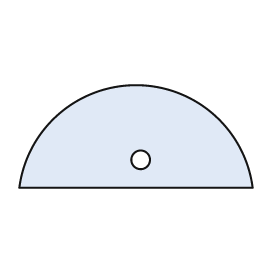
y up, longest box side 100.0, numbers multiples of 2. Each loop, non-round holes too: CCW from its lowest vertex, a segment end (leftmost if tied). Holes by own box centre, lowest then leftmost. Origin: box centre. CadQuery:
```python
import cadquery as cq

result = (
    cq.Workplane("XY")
    .moveTo(-50.0, -22.0)
    .lineTo(50.0, -22.0)
    .threePointArc((0.0, 22.0), (-50.0, -22.0))
    .close()
    .moveTo(2.0, -10.0)
    .circle(4.0)
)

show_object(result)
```